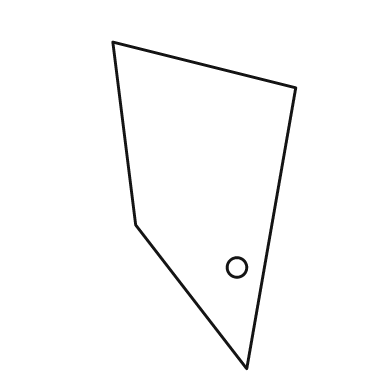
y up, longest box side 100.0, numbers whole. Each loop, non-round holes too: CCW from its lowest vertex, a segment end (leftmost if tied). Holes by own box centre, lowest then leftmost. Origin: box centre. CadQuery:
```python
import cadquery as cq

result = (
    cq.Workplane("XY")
    .moveTo(13.0, -50.0)
    .lineTo(28.0, 36.0)
    .lineTo(-28.0, 50.0)
    .lineTo(-21.0, -6.0)
    .close()
    .moveTo(10.0, -19.0)
    .circle(3.0)
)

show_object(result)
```